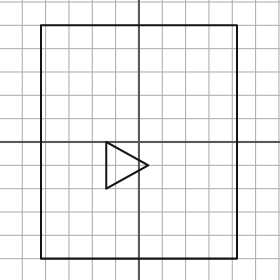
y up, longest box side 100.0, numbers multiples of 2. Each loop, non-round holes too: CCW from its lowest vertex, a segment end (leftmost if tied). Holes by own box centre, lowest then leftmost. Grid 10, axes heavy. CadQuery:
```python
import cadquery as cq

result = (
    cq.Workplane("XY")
    .moveTo(-42.0, -50.0)
    .lineTo(42.0, -50.0)
    .lineTo(42.0, 50.0)
    .lineTo(-42.0, 50.0)
    .close()
    .moveTo(-14.0, -20.0)
    .lineTo(4.0, -10.0)
    .lineTo(-14.0, 0.0)
    .close()
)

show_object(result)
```